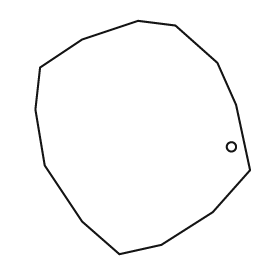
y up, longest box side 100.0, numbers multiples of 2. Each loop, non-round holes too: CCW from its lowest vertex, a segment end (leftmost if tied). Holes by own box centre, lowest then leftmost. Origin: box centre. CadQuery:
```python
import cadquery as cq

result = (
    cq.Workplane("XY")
    .moveTo(-10.0, -50.0)
    .lineTo(8.0, -46.0)
    .lineTo(30.0, -32.0)
    .lineTo(46.0, -14.0)
    .lineTo(40.0, 14.0)
    .lineTo(32.0, 32.0)
    .lineTo(14.0, 48.0)
    .lineTo(-2.0, 50.0)
    .lineTo(-26.0, 42.0)
    .lineTo(-44.0, 30.0)
    .lineTo(-46.0, 12.0)
    .lineTo(-42.0, -12.0)
    .lineTo(-26.0, -36.0)
    .close()
    .moveTo(38.0, -4.0)
    .circle(2.0)
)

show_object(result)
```